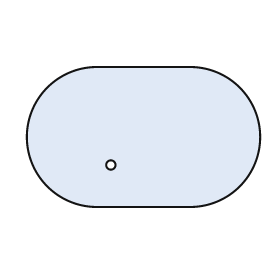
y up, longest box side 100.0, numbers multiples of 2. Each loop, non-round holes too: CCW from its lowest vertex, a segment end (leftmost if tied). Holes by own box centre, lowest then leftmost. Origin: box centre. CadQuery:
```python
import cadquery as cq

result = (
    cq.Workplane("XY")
    .moveTo(-20.0, -30.0)
    .lineTo(20.0, -30.0)
    .threePointArc((50.0, 0.0), (20.0, 30.0))
    .lineTo(-20.0, 30.0)
    .threePointArc((-50.0, 0.0), (-20.0, -30.0))
    .close()
    .moveTo(-14.0, -12.0)
    .circle(2.0)
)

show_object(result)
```